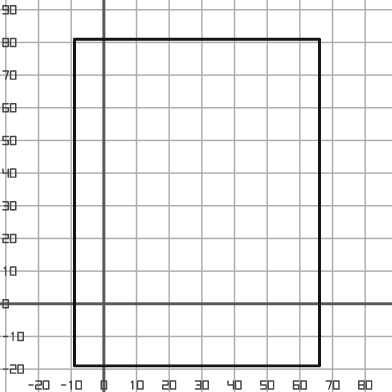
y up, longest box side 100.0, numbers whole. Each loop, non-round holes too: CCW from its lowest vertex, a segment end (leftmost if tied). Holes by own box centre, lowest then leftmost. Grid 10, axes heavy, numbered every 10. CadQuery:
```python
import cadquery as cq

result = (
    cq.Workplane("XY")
    .moveTo(-9.0, -19.0)
    .lineTo(66.0, -19.0)
    .lineTo(66.0, 81.0)
    .lineTo(-9.0, 81.0)
    .close()
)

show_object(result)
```